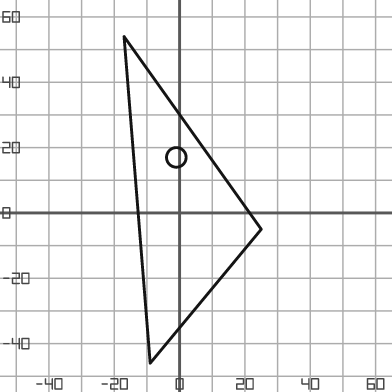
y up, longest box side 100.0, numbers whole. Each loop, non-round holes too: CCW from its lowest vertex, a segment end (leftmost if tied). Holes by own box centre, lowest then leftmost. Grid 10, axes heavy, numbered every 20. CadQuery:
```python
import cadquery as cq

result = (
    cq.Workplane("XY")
    .moveTo(-9.0, -46.0)
    .lineTo(25.0, -5.0)
    .lineTo(-17.0, 54.0)
    .close()
    .moveTo(-1.0, 17.0)
    .circle(3.0)
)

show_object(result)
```